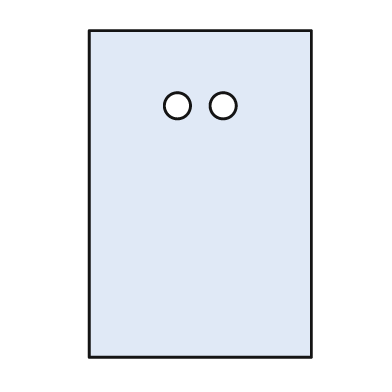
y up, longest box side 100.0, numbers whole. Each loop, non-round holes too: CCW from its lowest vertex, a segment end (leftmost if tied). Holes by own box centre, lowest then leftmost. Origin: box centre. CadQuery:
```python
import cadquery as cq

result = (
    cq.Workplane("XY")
    .moveTo(-34.0, -50.0)
    .lineTo(34.0, -50.0)
    .lineTo(34.0, 50.0)
    .lineTo(-34.0, 50.0)
    .close()
    .moveTo(-7.0, 27.0)
    .circle(4.0)
    .moveTo(7.0, 27.0)
    .circle(4.0)
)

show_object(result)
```